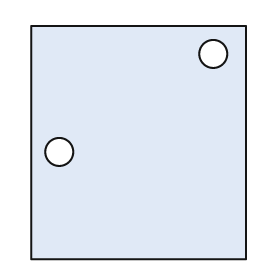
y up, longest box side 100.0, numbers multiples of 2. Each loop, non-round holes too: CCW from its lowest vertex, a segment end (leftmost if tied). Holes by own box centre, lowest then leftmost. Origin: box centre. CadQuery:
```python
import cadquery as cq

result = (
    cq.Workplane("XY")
    .moveTo(-46.0, -50.0)
    .lineTo(46.0, -50.0)
    .lineTo(46.0, 50.0)
    .lineTo(-46.0, 50.0)
    .close()
    .moveTo(-34.0, -4.0)
    .circle(6.0)
    .moveTo(32.0, 38.0)
    .circle(6.0)
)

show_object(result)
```